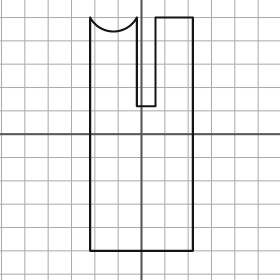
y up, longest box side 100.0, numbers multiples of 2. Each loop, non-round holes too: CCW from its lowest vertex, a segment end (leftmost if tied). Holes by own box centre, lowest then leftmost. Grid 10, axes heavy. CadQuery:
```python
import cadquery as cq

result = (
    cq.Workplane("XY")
    .moveTo(-22.0, -50.0)
    .lineTo(22.0, -50.0)
    .lineTo(22.0, 50.0)
    .lineTo(6.0, 50.0)
    .lineTo(6.0, 12.0)
    .lineTo(-2.0, 12.0)
    .lineTo(-2.0, 50.0)
    .threePointArc((-12.0, 44.0), (-22.0, 50.0))
    .close()
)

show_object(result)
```